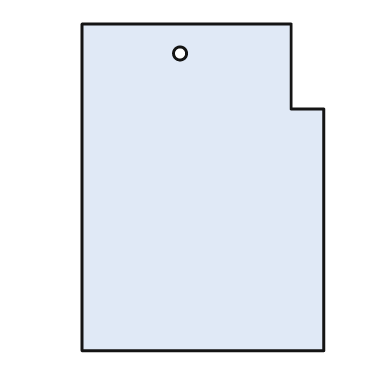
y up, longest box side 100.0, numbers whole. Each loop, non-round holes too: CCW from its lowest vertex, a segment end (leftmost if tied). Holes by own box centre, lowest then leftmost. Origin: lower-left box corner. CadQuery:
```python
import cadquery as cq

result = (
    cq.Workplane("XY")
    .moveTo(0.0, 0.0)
    .lineTo(74.0, 0.0)
    .lineTo(74.0, 74.0)
    .lineTo(64.0, 74.0)
    .lineTo(64.0, 100.0)
    .lineTo(0.0, 100.0)
    .close()
    .moveTo(30.0, 91.0)
    .circle(2.0)
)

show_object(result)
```